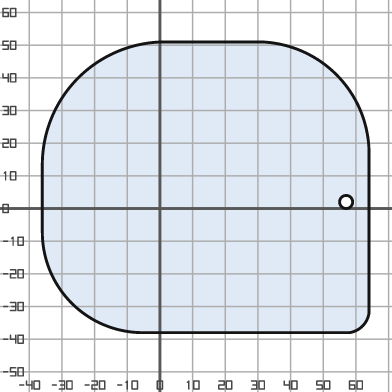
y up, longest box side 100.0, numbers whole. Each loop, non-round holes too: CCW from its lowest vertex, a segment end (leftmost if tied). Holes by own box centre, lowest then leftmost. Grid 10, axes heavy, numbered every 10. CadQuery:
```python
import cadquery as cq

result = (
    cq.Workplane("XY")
    .moveTo(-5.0, -38.0)
    .lineTo(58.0, -38.0)
    .threePointArc((62.0, -36.0), (64.0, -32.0))
    .lineTo(64.0, 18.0)
    .threePointArc((54.0, 41.0), (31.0, 51.0))
    .lineTo(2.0, 51.0)
    .threePointArc((-25.0, 40.0), (-36.0, 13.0))
    .lineTo(-36.0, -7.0)
    .threePointArc((-27.0, -29.0), (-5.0, -38.0))
    .close()
    .moveTo(57.0, 2.0)
    .circle(2.0)
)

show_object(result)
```